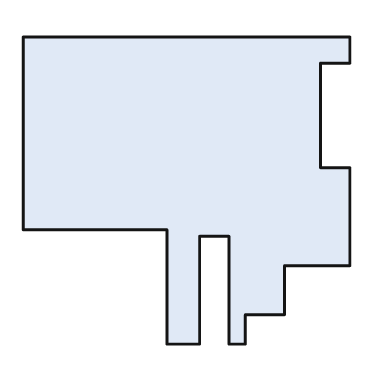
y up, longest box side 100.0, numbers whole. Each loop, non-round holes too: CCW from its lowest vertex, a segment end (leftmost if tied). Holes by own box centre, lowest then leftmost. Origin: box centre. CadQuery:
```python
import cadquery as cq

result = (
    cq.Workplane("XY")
    .moveTo(-6.0, -47.0)
    .lineTo(4.0, -47.0)
    .lineTo(4.0, -14.0)
    .lineTo(13.0, -14.0)
    .lineTo(13.0, -47.0)
    .lineTo(18.0, -47.0)
    .lineTo(18.0, -38.0)
    .lineTo(30.0, -38.0)
    .lineTo(30.0, -23.0)
    .lineTo(50.0, -23.0)
    .lineTo(50.0, 7.0)
    .lineTo(41.0, 7.0)
    .lineTo(41.0, 39.0)
    .lineTo(50.0, 39.0)
    .lineTo(50.0, 47.0)
    .lineTo(-50.0, 47.0)
    .lineTo(-50.0, -12.0)
    .lineTo(-6.0, -12.0)
    .close()
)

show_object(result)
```